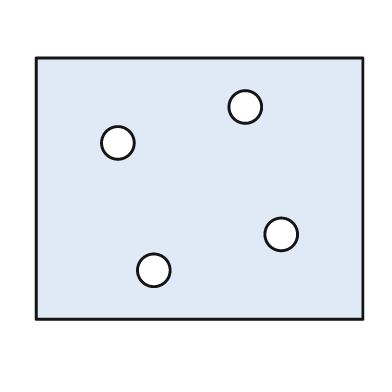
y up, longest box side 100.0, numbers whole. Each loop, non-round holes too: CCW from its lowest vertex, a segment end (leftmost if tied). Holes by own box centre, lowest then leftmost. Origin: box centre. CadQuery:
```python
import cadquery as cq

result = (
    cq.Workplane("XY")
    .moveTo(-50.0, -40.0)
    .lineTo(50.0, -40.0)
    .lineTo(50.0, 40.0)
    .lineTo(-50.0, 40.0)
    .close()
    .moveTo(-14.0, -25.0)
    .circle(5.0)
    .moveTo(25.0, -14.0)
    .circle(5.0)
    .moveTo(-25.0, 14.0)
    .circle(5.0)
    .moveTo(14.0, 25.0)
    .circle(5.0)
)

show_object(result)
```